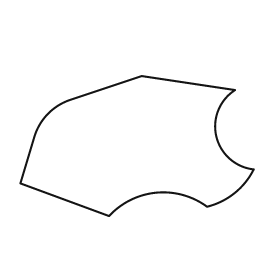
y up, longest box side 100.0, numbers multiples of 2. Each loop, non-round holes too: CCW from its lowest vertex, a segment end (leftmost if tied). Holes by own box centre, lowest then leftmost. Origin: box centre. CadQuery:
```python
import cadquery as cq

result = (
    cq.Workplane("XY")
    .moveTo(-12.0, -30.0)
    .threePointArc((8.0, -20.0), (30.0, -26.0))
    .threePointArc((42.0, -20.0), (50.0, -10.0))
    .threePointArc((34.0, 4.0), (42.0, 24.0))
    .lineTo(2.0, 30.0)
    .lineTo(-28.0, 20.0)
    .threePointArc((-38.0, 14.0), (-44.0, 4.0))
    .lineTo(-50.0, -16.0)
    .close()
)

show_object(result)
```